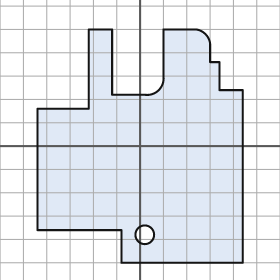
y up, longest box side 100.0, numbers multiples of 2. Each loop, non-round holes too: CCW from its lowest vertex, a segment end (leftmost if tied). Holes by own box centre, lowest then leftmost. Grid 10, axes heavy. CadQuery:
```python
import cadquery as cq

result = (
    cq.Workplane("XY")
    .moveTo(-8.0, -50.0)
    .lineTo(44.0, -50.0)
    .lineTo(44.0, 24.0)
    .lineTo(34.0, 24.0)
    .lineTo(34.0, 36.0)
    .lineTo(30.0, 36.0)
    .lineTo(30.0, 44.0)
    .threePointArc((28.0, 48.0), (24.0, 50.0))
    .lineTo(10.0, 50.0)
    .lineTo(10.0, 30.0)
    .threePointArc((8.0, 24.0), (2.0, 22.0))
    .lineTo(-12.0, 22.0)
    .lineTo(-12.0, 50.0)
    .lineTo(-22.0, 50.0)
    .lineTo(-22.0, 16.0)
    .lineTo(-44.0, 16.0)
    .lineTo(-44.0, -36.0)
    .lineTo(-8.0, -36.0)
    .close()
    .moveTo(2.0, -38.0)
    .circle(4.0)
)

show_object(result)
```